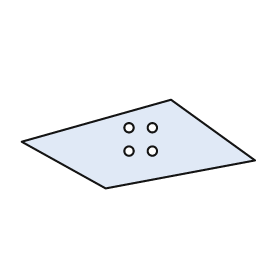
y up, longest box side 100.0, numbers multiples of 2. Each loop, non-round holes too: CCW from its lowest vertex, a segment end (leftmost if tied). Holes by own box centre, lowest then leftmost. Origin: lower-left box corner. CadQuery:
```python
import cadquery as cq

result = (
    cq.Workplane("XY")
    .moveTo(36.0, 0.0)
    .lineTo(100.0, 12.0)
    .lineTo(64.0, 38.0)
    .lineTo(0.0, 20.0)
    .close()
    .moveTo(46.0, 16.0)
    .circle(2.0)
    .moveTo(56.0, 16.0)
    .circle(2.0)
    .moveTo(46.0, 26.0)
    .circle(2.0)
    .moveTo(56.0, 26.0)
    .circle(2.0)
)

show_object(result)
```